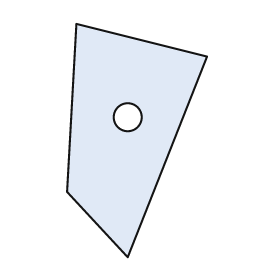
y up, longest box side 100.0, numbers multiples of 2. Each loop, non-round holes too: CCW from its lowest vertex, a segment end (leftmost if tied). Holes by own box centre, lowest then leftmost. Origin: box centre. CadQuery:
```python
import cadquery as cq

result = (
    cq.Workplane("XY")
    .moveTo(-4.0, -50.0)
    .lineTo(30.0, 36.0)
    .lineTo(-26.0, 50.0)
    .lineTo(-30.0, -22.0)
    .close()
    .moveTo(-4.0, 10.0)
    .circle(6.0)
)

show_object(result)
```